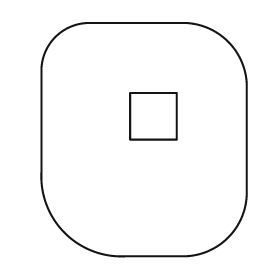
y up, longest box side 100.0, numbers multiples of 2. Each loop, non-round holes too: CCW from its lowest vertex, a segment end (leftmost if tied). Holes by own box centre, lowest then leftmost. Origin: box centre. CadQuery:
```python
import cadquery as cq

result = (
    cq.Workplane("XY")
    .moveTo(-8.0, -50.0)
    .lineTo(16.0, -50.0)
    .threePointArc((36.0, -42.0), (44.0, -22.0))
    .lineTo(44.0, 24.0)
    .threePointArc((36.0, 42.0), (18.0, 50.0))
    .lineTo(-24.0, 50.0)
    .threePointArc((-38.0, 44.0), (-44.0, 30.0))
    .lineTo(-44.0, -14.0)
    .threePointArc((-34.0, -40.0), (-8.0, -50.0))
    .close()
    .moveTo(-6.0, 0.0)
    .lineTo(14.0, 0.0)
    .lineTo(14.0, 20.0)
    .lineTo(-6.0, 20.0)
    .close()
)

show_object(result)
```